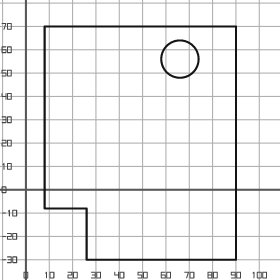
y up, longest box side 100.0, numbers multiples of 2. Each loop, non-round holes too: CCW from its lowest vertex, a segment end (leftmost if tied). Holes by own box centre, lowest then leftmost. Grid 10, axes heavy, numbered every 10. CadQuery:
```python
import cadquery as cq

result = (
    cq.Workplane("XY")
    .moveTo(26.0, -30.0)
    .lineTo(90.0, -30.0)
    .lineTo(90.0, 70.0)
    .lineTo(8.0, 70.0)
    .lineTo(8.0, -8.0)
    .lineTo(26.0, -8.0)
    .close()
    .moveTo(66.0, 56.0)
    .circle(8.0)
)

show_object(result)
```